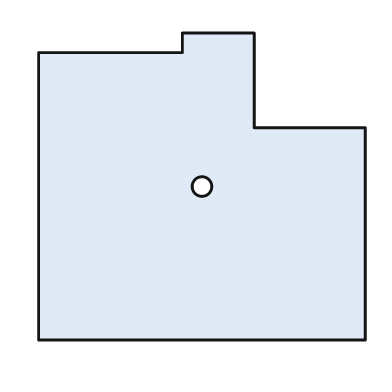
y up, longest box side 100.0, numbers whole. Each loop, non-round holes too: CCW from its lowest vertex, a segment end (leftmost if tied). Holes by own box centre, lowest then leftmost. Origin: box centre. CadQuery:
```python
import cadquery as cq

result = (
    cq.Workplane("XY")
    .moveTo(-50.0, -47.0)
    .lineTo(50.0, -47.0)
    .lineTo(50.0, 18.0)
    .lineTo(16.0, 18.0)
    .lineTo(16.0, 47.0)
    .lineTo(-6.0, 47.0)
    .lineTo(-6.0, 41.0)
    .lineTo(-50.0, 41.0)
    .close()
    .moveTo(0.0, 0.0)
    .circle(3.0)
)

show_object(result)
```